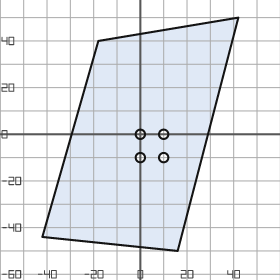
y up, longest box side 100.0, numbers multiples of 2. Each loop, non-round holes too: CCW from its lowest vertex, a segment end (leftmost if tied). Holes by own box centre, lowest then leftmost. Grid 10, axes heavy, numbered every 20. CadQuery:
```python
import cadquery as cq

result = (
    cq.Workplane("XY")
    .moveTo(16.0, -50.0)
    .lineTo(42.0, 50.0)
    .lineTo(-18.0, 40.0)
    .lineTo(-42.0, -44.0)
    .close()
    .moveTo(0.0, -10.0)
    .circle(2.0)
    .moveTo(10.0, -10.0)
    .circle(2.0)
    .moveTo(0.0, 0.0)
    .circle(2.0)
    .moveTo(10.0, 0.0)
    .circle(2.0)
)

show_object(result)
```